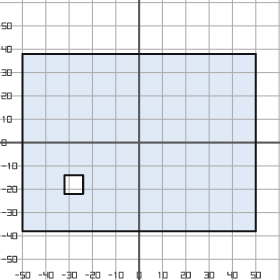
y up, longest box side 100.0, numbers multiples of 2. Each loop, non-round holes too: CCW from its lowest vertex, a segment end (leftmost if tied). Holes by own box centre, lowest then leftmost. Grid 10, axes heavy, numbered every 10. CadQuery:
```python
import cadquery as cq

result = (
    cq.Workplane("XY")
    .moveTo(-50.0, -38.0)
    .lineTo(50.0, -38.0)
    .lineTo(50.0, 38.0)
    .lineTo(-50.0, 38.0)
    .close()
    .moveTo(-32.0, -22.0)
    .lineTo(-24.0, -22.0)
    .lineTo(-24.0, -14.0)
    .lineTo(-32.0, -14.0)
    .close()
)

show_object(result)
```